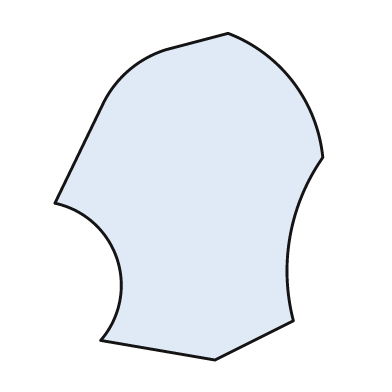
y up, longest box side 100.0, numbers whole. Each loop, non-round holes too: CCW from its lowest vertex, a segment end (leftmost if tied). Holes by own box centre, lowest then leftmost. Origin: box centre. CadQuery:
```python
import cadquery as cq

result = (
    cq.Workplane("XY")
    .moveTo(8.0, -50.0)
    .lineTo(32.0, -38.0)
    .threePointArc((31.0, -12.0), (41.0, 12.0))
    .threePointArc((32.0, 35.0), (12.0, 50.0))
    .lineTo(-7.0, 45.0)
    .threePointArc((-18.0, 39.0), (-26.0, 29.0))
    .lineTo(-41.0, -2.0)
    .threePointArc((-22.0, -19.0), (-27.0, -44.0))
    .close()
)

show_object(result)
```